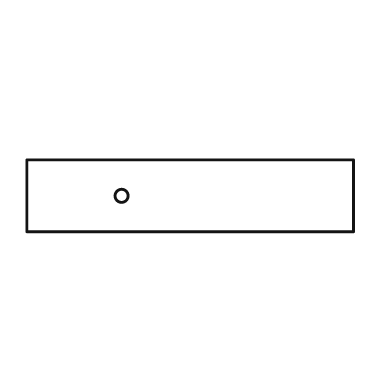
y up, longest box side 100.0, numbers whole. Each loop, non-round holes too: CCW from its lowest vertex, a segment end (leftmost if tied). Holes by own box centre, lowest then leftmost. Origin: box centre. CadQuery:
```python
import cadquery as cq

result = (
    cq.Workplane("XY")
    .moveTo(-50.0, -11.0)
    .lineTo(50.0, -11.0)
    .lineTo(50.0, 11.0)
    .lineTo(-50.0, 11.0)
    .close()
    .moveTo(-21.0, 0.0)
    .circle(2.0)
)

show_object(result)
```